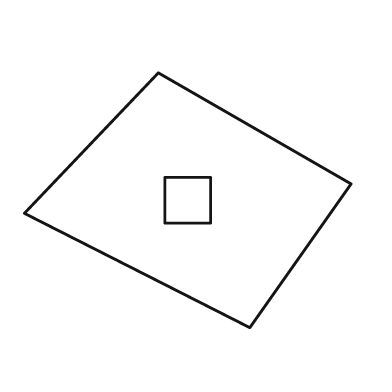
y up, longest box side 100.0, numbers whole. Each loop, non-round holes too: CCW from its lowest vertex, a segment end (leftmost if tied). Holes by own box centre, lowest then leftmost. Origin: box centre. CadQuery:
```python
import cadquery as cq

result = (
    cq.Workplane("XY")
    .moveTo(19.0, -39.0)
    .lineTo(50.0, 5.0)
    .lineTo(-9.0, 39.0)
    .lineTo(-50.0, -4.0)
    .close()
    .moveTo(-7.0, -7.0)
    .lineTo(7.0, -7.0)
    .lineTo(7.0, 7.0)
    .lineTo(-7.0, 7.0)
    .close()
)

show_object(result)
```